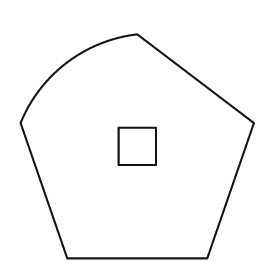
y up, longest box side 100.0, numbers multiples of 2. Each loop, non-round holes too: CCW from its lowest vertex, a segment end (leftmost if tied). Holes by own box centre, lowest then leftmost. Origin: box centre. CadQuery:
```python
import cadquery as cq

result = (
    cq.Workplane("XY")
    .moveTo(-30.0, -48.0)
    .lineTo(30.0, -48.0)
    .lineTo(50.0, 10.0)
    .lineTo(0.0, 48.0)
    .threePointArc((-30.0, 36.0), (-50.0, 10.0))
    .close()
    .moveTo(-8.0, -8.0)
    .lineTo(8.0, -8.0)
    .lineTo(8.0, 8.0)
    .lineTo(-8.0, 8.0)
    .close()
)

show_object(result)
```